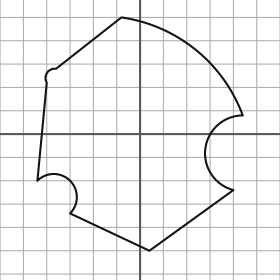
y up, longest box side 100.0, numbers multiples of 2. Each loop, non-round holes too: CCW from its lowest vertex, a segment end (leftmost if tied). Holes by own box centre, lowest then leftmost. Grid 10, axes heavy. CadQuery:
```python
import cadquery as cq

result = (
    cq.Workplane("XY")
    .moveTo(4.0, -50.0)
    .lineTo(40.0, -24.0)
    .threePointArc((28.0, -6.0), (44.0, 8.0))
    .threePointArc((24.0, 36.0), (-8.0, 50.0))
    .lineTo(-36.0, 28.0)
    .threePointArc((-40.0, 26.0), (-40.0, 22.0))
    .lineTo(-44.0, -20.0)
    .threePointArc((-30.0, -20.0), (-30.0, -34.0))
    .close()
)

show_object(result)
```